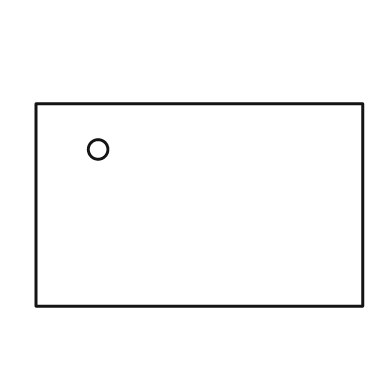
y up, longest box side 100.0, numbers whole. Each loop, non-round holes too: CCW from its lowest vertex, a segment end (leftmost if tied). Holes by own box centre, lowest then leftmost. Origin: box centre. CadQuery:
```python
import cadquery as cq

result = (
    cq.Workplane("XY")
    .moveTo(-50.0, -31.0)
    .lineTo(50.0, -31.0)
    .lineTo(50.0, 31.0)
    .lineTo(-50.0, 31.0)
    .close()
    .moveTo(-31.0, 17.0)
    .circle(3.0)
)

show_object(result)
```